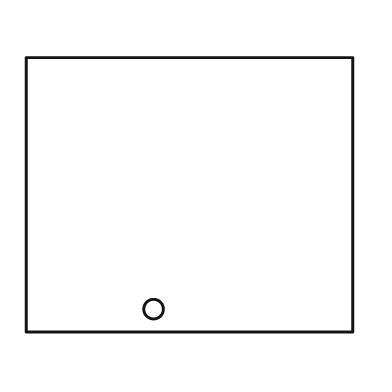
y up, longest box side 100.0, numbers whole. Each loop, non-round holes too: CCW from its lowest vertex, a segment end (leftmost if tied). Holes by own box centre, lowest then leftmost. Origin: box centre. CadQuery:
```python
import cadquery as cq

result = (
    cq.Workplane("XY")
    .moveTo(-50.0, -42.0)
    .lineTo(50.0, -42.0)
    .lineTo(50.0, 42.0)
    .lineTo(-50.0, 42.0)
    .close()
    .moveTo(-11.0, -35.0)
    .circle(3.0)
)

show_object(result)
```